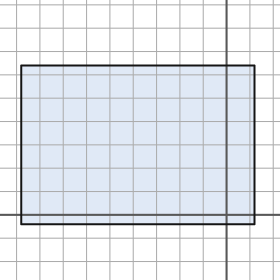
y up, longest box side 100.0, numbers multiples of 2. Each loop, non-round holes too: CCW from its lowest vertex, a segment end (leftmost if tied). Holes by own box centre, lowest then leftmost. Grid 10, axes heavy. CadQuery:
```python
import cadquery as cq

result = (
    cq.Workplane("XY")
    .moveTo(-88.0, -4.0)
    .lineTo(12.0, -4.0)
    .lineTo(12.0, 64.0)
    .lineTo(-88.0, 64.0)
    .close()
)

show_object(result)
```